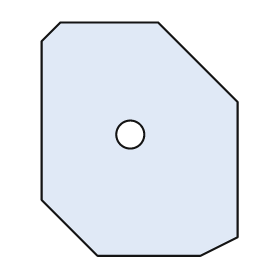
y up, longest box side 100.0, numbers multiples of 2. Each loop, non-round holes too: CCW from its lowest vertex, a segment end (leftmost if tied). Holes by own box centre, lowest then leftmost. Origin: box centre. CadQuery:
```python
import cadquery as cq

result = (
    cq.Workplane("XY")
    .moveTo(-18.0, -50.0)
    .lineTo(26.0, -50.0)
    .lineTo(42.0, -42.0)
    .lineTo(42.0, 16.0)
    .lineTo(8.0, 50.0)
    .lineTo(-34.0, 50.0)
    .lineTo(-42.0, 42.0)
    .lineTo(-42.0, -26.0)
    .close()
    .moveTo(-4.0, 2.0)
    .circle(6.0)
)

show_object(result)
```